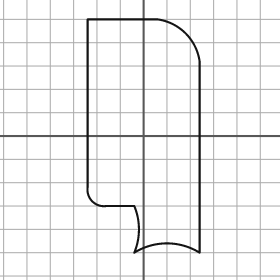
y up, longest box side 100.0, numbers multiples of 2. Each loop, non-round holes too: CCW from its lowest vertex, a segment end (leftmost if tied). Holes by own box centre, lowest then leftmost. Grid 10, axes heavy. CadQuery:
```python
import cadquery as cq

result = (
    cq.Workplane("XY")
    .moveTo(-4.0, -50.0)
    .threePointArc((10.0, -46.0), (24.0, -50.0))
    .lineTo(24.0, 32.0)
    .threePointArc((18.0, 44.0), (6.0, 50.0))
    .lineTo(-24.0, 50.0)
    .lineTo(-24.0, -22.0)
    .threePointArc((-22.0, -28.0), (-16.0, -30.0))
    .lineTo(-4.0, -30.0)
    .threePointArc((-2.0, -40.0), (-4.0, -50.0))
    .close()
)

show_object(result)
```